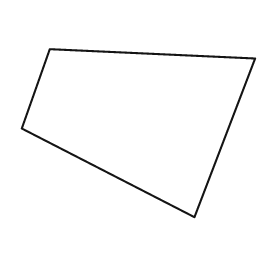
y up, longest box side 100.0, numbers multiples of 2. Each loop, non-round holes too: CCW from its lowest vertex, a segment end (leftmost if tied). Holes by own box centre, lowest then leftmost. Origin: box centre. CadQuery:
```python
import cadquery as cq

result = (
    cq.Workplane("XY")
    .moveTo(24.0, -36.0)
    .lineTo(50.0, 32.0)
    .lineTo(-38.0, 36.0)
    .lineTo(-50.0, 2.0)
    .close()
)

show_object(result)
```